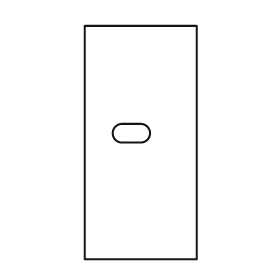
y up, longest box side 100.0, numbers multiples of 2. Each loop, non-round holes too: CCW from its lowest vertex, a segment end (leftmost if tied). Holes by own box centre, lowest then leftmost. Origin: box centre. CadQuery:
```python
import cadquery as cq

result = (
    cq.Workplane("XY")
    .moveTo(-24.0, -50.0)
    .lineTo(24.0, -50.0)
    .lineTo(24.0, 50.0)
    .lineTo(-24.0, 50.0)
    .close()
    .moveTo(-8.0, 0.0)
    .lineTo(0.0, 0.0)
    .threePointArc((4.0, 4.0), (0.0, 8.0))
    .lineTo(-8.0, 8.0)
    .threePointArc((-12.0, 4.0), (-8.0, 0.0))
    .close()
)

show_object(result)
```